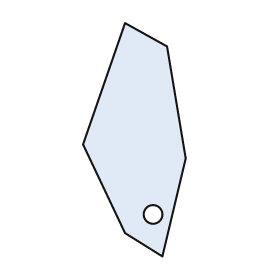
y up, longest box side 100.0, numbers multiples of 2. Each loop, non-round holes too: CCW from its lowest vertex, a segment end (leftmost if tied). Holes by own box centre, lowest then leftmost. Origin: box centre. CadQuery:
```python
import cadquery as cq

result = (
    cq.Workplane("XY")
    .moveTo(12.0, -50.0)
    .lineTo(22.0, -8.0)
    .lineTo(14.0, 40.0)
    .lineTo(-4.0, 50.0)
    .lineTo(-22.0, -2.0)
    .lineTo(-4.0, -40.0)
    .close()
    .moveTo(8.0, -32.0)
    .circle(4.0)
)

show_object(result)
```